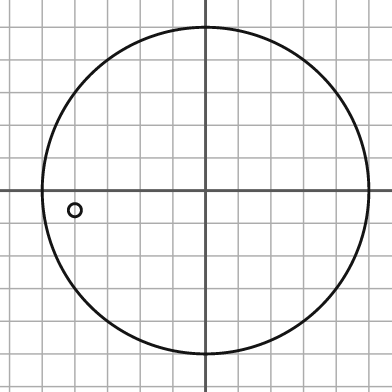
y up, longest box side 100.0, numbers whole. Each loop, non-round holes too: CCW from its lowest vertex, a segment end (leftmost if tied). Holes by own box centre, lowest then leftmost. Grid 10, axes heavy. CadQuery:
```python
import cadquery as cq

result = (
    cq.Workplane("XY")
    .moveTo(0.0, 0.0)
    .circle(50.0)
    .moveTo(-40.0, -6.0)
    .circle(2.0)
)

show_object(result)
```